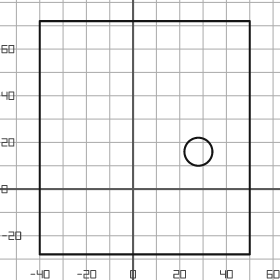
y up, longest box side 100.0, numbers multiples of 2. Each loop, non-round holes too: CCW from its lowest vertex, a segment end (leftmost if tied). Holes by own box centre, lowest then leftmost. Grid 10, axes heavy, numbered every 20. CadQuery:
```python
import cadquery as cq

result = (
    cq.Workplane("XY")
    .moveTo(-40.0, -28.0)
    .lineTo(50.0, -28.0)
    .lineTo(50.0, 72.0)
    .lineTo(-40.0, 72.0)
    .close()
    .moveTo(28.0, 16.0)
    .circle(6.0)
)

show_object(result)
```